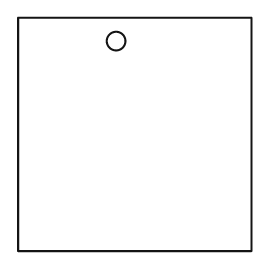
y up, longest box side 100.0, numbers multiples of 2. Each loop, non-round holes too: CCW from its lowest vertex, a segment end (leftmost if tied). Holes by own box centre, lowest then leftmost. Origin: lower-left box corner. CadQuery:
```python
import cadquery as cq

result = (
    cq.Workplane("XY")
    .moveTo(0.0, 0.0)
    .lineTo(100.0, 0.0)
    .lineTo(100.0, 100.0)
    .lineTo(0.0, 100.0)
    .close()
    .moveTo(42.0, 90.0)
    .circle(4.0)
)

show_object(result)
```